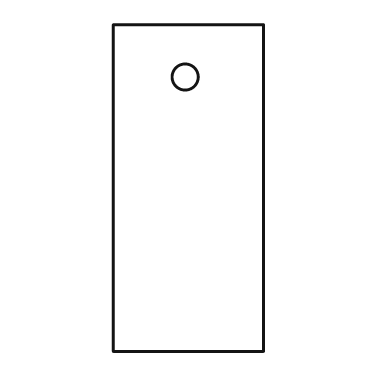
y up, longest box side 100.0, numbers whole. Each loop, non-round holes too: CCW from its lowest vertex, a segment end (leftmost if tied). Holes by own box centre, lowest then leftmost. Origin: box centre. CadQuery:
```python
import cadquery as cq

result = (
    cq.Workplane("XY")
    .moveTo(-23.0, -50.0)
    .lineTo(23.0, -50.0)
    .lineTo(23.0, 50.0)
    .lineTo(-23.0, 50.0)
    .close()
    .moveTo(-1.0, 34.0)
    .circle(4.0)
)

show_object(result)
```